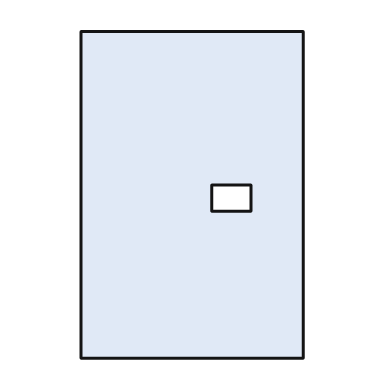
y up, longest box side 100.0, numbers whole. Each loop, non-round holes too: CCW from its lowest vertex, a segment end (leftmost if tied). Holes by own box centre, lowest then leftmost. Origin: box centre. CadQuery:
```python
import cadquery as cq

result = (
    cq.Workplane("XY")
    .moveTo(-34.0, -50.0)
    .lineTo(34.0, -50.0)
    .lineTo(34.0, 50.0)
    .lineTo(-34.0, 50.0)
    .close()
    .moveTo(6.0, -5.0)
    .lineTo(18.0, -5.0)
    .lineTo(18.0, 3.0)
    .lineTo(6.0, 3.0)
    .close()
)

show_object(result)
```